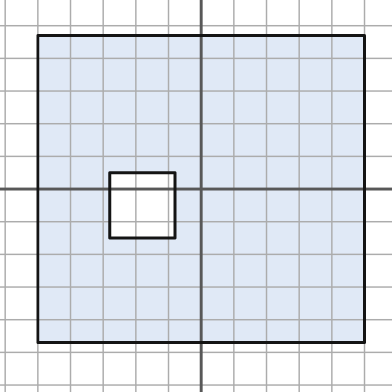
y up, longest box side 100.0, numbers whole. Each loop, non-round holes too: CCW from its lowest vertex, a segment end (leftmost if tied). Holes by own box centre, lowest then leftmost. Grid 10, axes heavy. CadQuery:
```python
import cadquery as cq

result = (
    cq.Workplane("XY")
    .moveTo(-50.0, -47.0)
    .lineTo(50.0, -47.0)
    .lineTo(50.0, 47.0)
    .lineTo(-50.0, 47.0)
    .close()
    .moveTo(-28.0, -15.0)
    .lineTo(-8.0, -15.0)
    .lineTo(-8.0, 5.0)
    .lineTo(-28.0, 5.0)
    .close()
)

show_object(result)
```